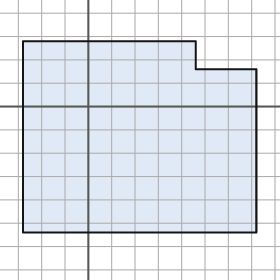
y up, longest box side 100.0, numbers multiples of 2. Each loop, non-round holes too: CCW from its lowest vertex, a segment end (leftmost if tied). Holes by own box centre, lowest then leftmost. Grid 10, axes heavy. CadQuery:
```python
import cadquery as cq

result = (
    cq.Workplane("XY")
    .moveTo(-28.0, -54.0)
    .lineTo(72.0, -54.0)
    .lineTo(72.0, 16.0)
    .lineTo(46.0, 16.0)
    .lineTo(46.0, 28.0)
    .lineTo(-28.0, 28.0)
    .close()
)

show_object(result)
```